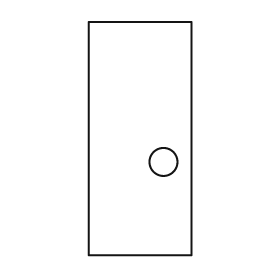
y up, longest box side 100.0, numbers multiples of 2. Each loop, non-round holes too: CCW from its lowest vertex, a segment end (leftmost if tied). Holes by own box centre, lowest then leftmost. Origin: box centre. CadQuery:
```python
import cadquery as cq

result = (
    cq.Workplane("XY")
    .moveTo(-22.0, -50.0)
    .lineTo(22.0, -50.0)
    .lineTo(22.0, 50.0)
    .lineTo(-22.0, 50.0)
    .close()
    .moveTo(10.0, -10.0)
    .circle(6.0)
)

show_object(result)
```